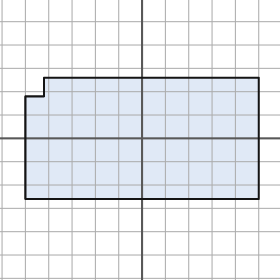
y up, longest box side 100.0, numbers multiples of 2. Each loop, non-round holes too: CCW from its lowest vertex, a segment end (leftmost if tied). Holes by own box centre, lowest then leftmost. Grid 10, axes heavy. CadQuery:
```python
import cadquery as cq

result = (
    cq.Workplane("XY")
    .moveTo(-50.0, -26.0)
    .lineTo(50.0, -26.0)
    .lineTo(50.0, 26.0)
    .lineTo(-42.0, 26.0)
    .lineTo(-42.0, 18.0)
    .lineTo(-50.0, 18.0)
    .close()
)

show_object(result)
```